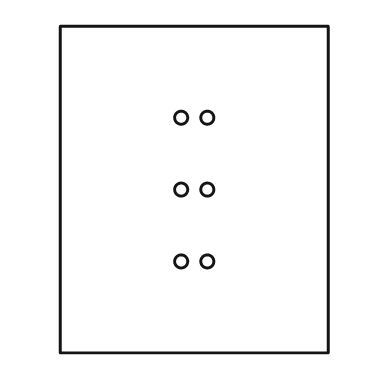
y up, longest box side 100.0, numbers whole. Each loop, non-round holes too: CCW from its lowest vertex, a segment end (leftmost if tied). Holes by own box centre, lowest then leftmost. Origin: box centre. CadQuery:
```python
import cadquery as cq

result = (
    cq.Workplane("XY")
    .moveTo(-41.0, -50.0)
    .lineTo(41.0, -50.0)
    .lineTo(41.0, 50.0)
    .lineTo(-41.0, 50.0)
    .close()
    .moveTo(-4.0, -22.0)
    .circle(2.0)
    .moveTo(4.0, -22.0)
    .circle(2.0)
    .moveTo(-4.0, 0.0)
    .circle(2.0)
    .moveTo(4.0, 0.0)
    .circle(2.0)
    .moveTo(-4.0, 22.0)
    .circle(2.0)
    .moveTo(4.0, 22.0)
    .circle(2.0)
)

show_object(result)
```